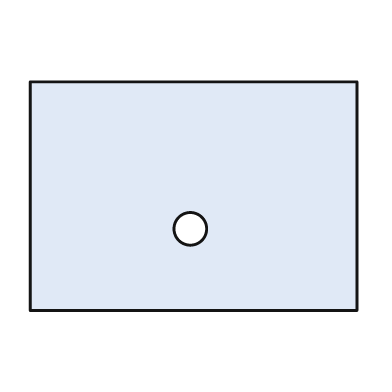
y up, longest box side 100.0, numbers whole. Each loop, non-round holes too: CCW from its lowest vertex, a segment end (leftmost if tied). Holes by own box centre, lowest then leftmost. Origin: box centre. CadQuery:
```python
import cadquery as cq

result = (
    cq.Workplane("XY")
    .moveTo(-50.0, -35.0)
    .lineTo(50.0, -35.0)
    .lineTo(50.0, 35.0)
    .lineTo(-50.0, 35.0)
    .close()
    .moveTo(-1.0, -10.0)
    .circle(5.0)
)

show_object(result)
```